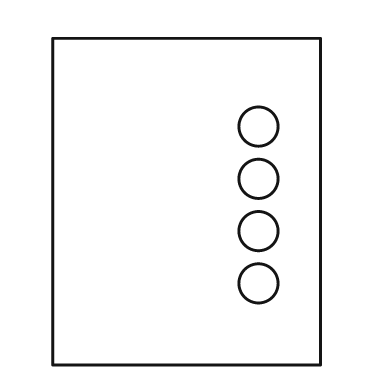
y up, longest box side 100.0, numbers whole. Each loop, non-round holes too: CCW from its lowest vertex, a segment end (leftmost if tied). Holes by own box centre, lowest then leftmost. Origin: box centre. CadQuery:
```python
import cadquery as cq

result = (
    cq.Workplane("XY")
    .moveTo(-41.0, -50.0)
    .lineTo(41.0, -50.0)
    .lineTo(41.0, 50.0)
    .lineTo(-41.0, 50.0)
    .close()
    .moveTo(22.0, -25.0)
    .circle(6.0)
    .moveTo(22.0, -9.0)
    .circle(6.0)
    .moveTo(22.0, 7.0)
    .circle(6.0)
    .moveTo(22.0, 23.0)
    .circle(6.0)
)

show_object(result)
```